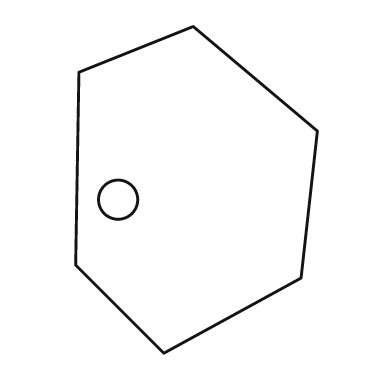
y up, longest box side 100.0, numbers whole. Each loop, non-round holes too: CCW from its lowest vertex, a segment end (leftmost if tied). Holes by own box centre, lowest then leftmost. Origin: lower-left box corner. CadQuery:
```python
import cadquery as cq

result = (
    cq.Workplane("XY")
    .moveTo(27.0, 0.0)
    .lineTo(69.0, 23.0)
    .lineTo(74.0, 68.0)
    .lineTo(36.0, 100.0)
    .lineTo(1.0, 86.0)
    .lineTo(0.0, 27.0)
    .close()
    .moveTo(13.0, 47.0)
    .circle(6.0)
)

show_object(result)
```